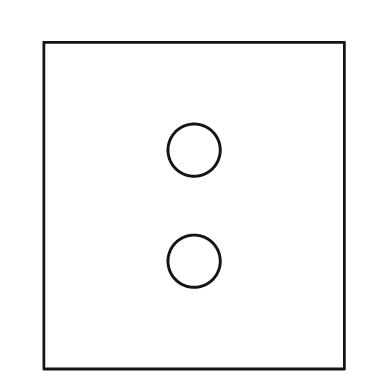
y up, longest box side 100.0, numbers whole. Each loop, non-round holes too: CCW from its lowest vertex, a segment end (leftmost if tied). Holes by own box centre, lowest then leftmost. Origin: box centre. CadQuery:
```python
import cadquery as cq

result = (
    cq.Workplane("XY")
    .moveTo(-46.0, -50.0)
    .lineTo(46.0, -50.0)
    .lineTo(46.0, 50.0)
    .lineTo(-46.0, 50.0)
    .close()
    .moveTo(0.0, -17.0)
    .circle(8.0)
    .moveTo(0.0, 17.0)
    .circle(8.0)
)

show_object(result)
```